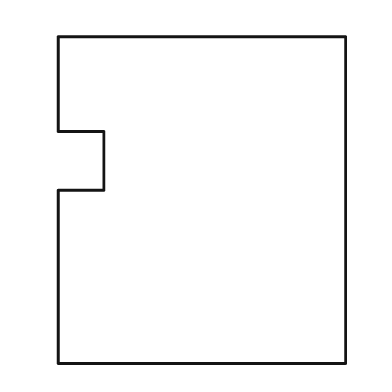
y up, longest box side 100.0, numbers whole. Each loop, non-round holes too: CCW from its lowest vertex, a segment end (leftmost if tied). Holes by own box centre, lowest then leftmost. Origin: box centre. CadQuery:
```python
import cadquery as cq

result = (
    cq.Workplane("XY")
    .moveTo(-44.0, -50.0)
    .lineTo(44.0, -50.0)
    .lineTo(44.0, 50.0)
    .lineTo(-44.0, 50.0)
    .lineTo(-44.0, 21.0)
    .lineTo(-30.0, 21.0)
    .lineTo(-30.0, 3.0)
    .lineTo(-44.0, 3.0)
    .close()
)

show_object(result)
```